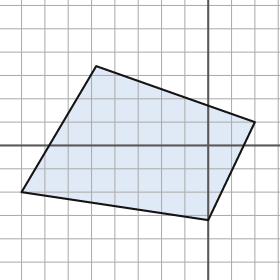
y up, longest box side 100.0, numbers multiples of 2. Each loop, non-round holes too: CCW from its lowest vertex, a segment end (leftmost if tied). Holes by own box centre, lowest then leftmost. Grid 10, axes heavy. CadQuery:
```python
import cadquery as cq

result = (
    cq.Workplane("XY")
    .moveTo(0.0, -32.0)
    .lineTo(20.0, 10.0)
    .lineTo(-48.0, 34.0)
    .lineTo(-80.0, -20.0)
    .close()
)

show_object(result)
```